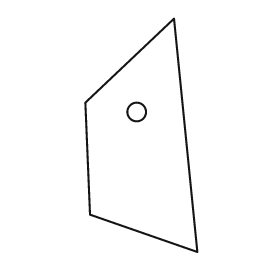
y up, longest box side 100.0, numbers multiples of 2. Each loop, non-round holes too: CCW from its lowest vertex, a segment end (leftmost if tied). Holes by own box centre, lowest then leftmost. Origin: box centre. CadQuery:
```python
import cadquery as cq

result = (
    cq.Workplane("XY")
    .moveTo(24.0, -50.0)
    .lineTo(14.0, 50.0)
    .lineTo(-24.0, 14.0)
    .lineTo(-22.0, -34.0)
    .close()
    .moveTo(-2.0, 10.0)
    .circle(4.0)
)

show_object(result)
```